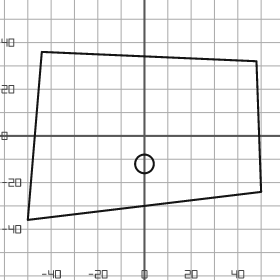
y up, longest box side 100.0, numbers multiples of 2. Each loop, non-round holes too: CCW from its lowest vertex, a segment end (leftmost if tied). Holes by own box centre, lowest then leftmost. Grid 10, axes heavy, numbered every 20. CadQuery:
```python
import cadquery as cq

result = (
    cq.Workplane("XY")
    .moveTo(-50.0, -36.0)
    .lineTo(50.0, -24.0)
    .lineTo(48.0, 32.0)
    .lineTo(-44.0, 36.0)
    .close()
    .moveTo(0.0, -12.0)
    .circle(4.0)
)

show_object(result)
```